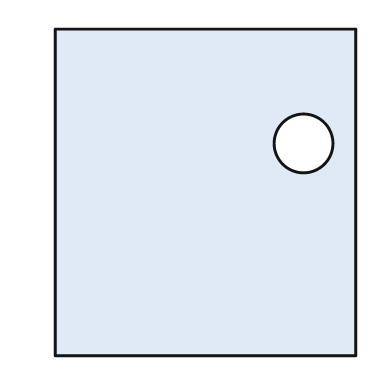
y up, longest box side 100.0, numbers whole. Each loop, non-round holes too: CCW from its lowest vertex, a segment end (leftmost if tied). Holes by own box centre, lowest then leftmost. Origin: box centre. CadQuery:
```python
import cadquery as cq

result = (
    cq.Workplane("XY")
    .moveTo(-46.0, -50.0)
    .lineTo(46.0, -50.0)
    .lineTo(46.0, 50.0)
    .lineTo(-46.0, 50.0)
    .close()
    .moveTo(30.0, 15.0)
    .circle(9.0)
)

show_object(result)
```